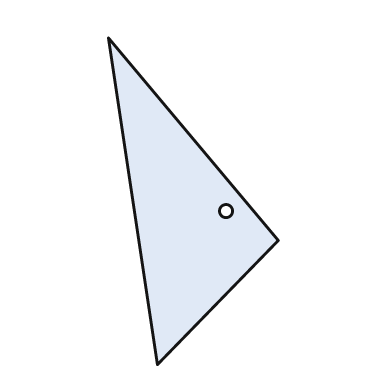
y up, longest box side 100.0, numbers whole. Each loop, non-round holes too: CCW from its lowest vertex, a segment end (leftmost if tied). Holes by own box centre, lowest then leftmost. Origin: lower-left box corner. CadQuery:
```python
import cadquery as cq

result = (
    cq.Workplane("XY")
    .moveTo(15.0, 0.0)
    .lineTo(52.0, 38.0)
    .lineTo(0.0, 100.0)
    .close()
    .moveTo(36.0, 47.0)
    .circle(2.0)
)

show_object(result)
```